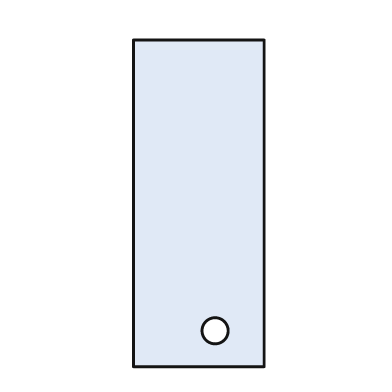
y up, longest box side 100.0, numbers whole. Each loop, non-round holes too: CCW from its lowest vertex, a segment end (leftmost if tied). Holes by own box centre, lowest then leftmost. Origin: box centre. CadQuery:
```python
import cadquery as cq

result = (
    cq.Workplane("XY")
    .moveTo(-20.0, -50.0)
    .lineTo(20.0, -50.0)
    .lineTo(20.0, 50.0)
    .lineTo(-20.0, 50.0)
    .close()
    .moveTo(5.0, -39.0)
    .circle(4.0)
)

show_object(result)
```